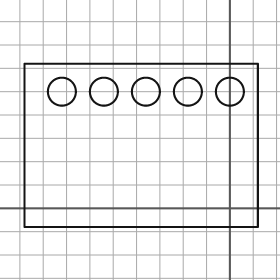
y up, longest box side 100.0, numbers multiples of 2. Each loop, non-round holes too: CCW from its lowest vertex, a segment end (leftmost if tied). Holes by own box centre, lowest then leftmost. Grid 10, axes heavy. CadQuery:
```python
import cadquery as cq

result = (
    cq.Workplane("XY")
    .moveTo(-88.0, -8.0)
    .lineTo(12.0, -8.0)
    .lineTo(12.0, 62.0)
    .lineTo(-88.0, 62.0)
    .close()
    .moveTo(-72.0, 50.0)
    .circle(6.0)
    .moveTo(-54.0, 50.0)
    .circle(6.0)
    .moveTo(-36.0, 50.0)
    .circle(6.0)
    .moveTo(-18.0, 50.0)
    .circle(6.0)
    .moveTo(0.0, 50.0)
    .circle(6.0)
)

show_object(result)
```